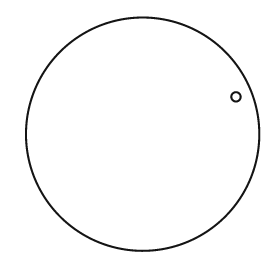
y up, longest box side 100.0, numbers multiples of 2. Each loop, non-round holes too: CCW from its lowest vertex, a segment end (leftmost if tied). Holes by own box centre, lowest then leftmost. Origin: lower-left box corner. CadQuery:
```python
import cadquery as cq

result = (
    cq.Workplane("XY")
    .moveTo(50.0, 50.0)
    .circle(50.0)
    .moveTo(90.0, 66.0)
    .circle(2.0)
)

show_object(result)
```